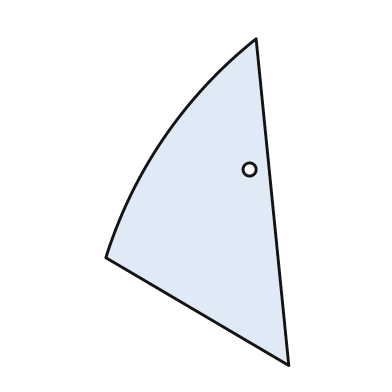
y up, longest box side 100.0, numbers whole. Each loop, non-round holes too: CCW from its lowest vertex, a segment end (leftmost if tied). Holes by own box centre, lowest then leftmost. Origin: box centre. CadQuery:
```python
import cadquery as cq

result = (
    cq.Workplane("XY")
    .moveTo(28.0, -50.0)
    .lineTo(18.0, 50.0)
    .threePointArc((-10.0, 20.0), (-28.0, -17.0))
    .close()
    .moveTo(16.0, 10.0)
    .circle(2.0)
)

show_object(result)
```